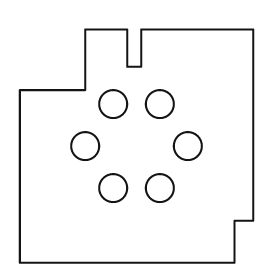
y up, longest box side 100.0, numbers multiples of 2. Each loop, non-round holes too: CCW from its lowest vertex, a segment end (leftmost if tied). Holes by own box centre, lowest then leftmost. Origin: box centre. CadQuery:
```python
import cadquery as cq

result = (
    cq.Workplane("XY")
    .moveTo(-50.0, -50.0)
    .lineTo(42.0, -50.0)
    .lineTo(42.0, -32.0)
    .lineTo(50.0, -32.0)
    .lineTo(50.0, 50.0)
    .lineTo(2.0, 50.0)
    .lineTo(2.0, 34.0)
    .lineTo(-4.0, 34.0)
    .lineTo(-4.0, 50.0)
    .lineTo(-22.0, 50.0)
    .lineTo(-22.0, 24.0)
    .lineTo(-50.0, 24.0)
    .close()
    .moveTo(-10.0, -18.0)
    .circle(6.0)
    .moveTo(10.0, -18.0)
    .circle(6.0)
    .moveTo(-22.0, 0.0)
    .circle(6.0)
    .moveTo(22.0, 0.0)
    .circle(6.0)
    .moveTo(-10.0, 18.0)
    .circle(6.0)
    .moveTo(10.0, 18.0)
    .circle(6.0)
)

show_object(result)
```